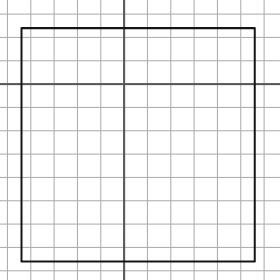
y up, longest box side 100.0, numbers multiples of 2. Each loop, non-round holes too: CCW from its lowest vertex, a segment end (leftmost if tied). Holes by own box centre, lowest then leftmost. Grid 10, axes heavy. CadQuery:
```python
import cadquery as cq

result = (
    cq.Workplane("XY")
    .moveTo(-44.0, -76.0)
    .lineTo(56.0, -76.0)
    .lineTo(56.0, 24.0)
    .lineTo(-44.0, 24.0)
    .close()
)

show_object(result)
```